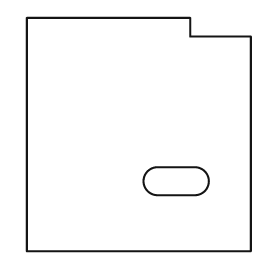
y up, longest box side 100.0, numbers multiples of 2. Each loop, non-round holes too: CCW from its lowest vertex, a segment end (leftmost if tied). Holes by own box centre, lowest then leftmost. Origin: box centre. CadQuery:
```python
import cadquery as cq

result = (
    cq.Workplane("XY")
    .moveTo(-48.0, -50.0)
    .lineTo(48.0, -50.0)
    .lineTo(48.0, 42.0)
    .lineTo(22.0, 42.0)
    .lineTo(22.0, 50.0)
    .lineTo(-48.0, 50.0)
    .close()
    .moveTo(8.0, -26.0)
    .lineTo(24.0, -26.0)
    .threePointArc((30.0, -20.0), (24.0, -14.0))
    .lineTo(8.0, -14.0)
    .threePointArc((2.0, -20.0), (8.0, -26.0))
    .close()
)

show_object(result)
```